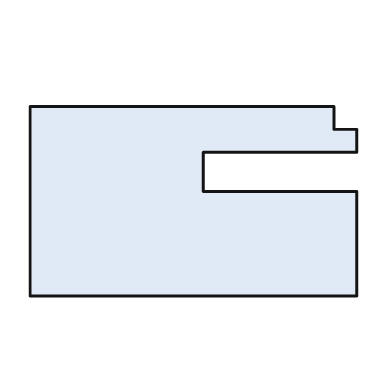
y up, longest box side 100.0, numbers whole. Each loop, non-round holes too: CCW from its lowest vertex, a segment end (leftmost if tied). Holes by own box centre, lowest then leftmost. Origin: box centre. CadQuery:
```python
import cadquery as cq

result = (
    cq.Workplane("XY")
    .moveTo(-50.0, -29.0)
    .lineTo(50.0, -29.0)
    .lineTo(50.0, 3.0)
    .lineTo(3.0, 3.0)
    .lineTo(3.0, 15.0)
    .lineTo(50.0, 15.0)
    .lineTo(50.0, 22.0)
    .lineTo(43.0, 22.0)
    .lineTo(43.0, 29.0)
    .lineTo(-50.0, 29.0)
    .close()
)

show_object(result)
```